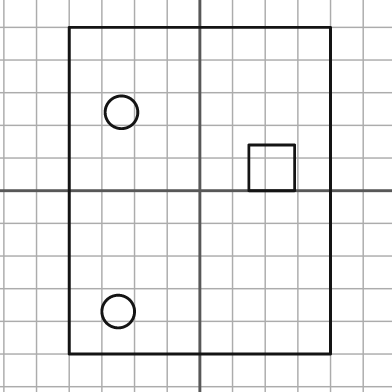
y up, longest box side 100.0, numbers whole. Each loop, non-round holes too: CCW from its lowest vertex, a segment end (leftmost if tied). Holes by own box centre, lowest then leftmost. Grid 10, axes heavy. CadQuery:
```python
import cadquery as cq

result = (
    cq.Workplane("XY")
    .moveTo(-40.0, -50.0)
    .lineTo(40.0, -50.0)
    .lineTo(40.0, 50.0)
    .lineTo(-40.0, 50.0)
    .close()
    .moveTo(-25.0, -37.0)
    .circle(5.0)
    .moveTo(15.0, 0.0)
    .lineTo(29.0, 0.0)
    .lineTo(29.0, 14.0)
    .lineTo(15.0, 14.0)
    .close()
    .moveTo(-24.0, 24.0)
    .circle(5.0)
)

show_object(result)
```